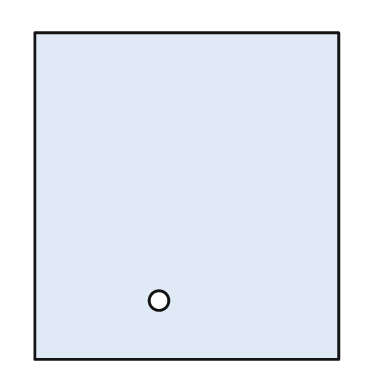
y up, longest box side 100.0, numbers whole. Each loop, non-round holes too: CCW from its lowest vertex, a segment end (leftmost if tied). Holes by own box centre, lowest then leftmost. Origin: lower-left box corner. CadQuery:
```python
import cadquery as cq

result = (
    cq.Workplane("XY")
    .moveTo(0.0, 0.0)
    .lineTo(93.0, 0.0)
    .lineTo(93.0, 100.0)
    .lineTo(0.0, 100.0)
    .close()
    .moveTo(38.0, 18.0)
    .circle(3.0)
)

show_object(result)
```